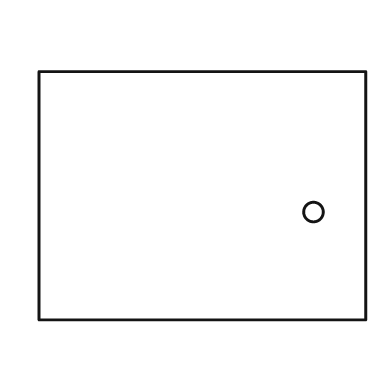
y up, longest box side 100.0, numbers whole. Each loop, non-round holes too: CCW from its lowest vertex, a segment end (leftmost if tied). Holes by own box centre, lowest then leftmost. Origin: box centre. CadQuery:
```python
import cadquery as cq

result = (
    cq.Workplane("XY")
    .moveTo(-50.0, -38.0)
    .lineTo(50.0, -38.0)
    .lineTo(50.0, 38.0)
    .lineTo(-50.0, 38.0)
    .close()
    .moveTo(34.0, -5.0)
    .circle(3.0)
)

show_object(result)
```